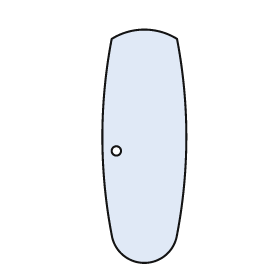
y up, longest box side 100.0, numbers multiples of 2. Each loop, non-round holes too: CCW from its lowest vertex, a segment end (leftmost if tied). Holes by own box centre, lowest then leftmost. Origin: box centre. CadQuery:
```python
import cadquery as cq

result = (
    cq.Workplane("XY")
    .moveTo(-14.0, -38.0)
    .threePointArc((0.0, -50.0), (14.0, -38.0))
    .threePointArc((18.0, 4.0), (14.0, 46.0))
    .threePointArc((0.0, 50.0), (-14.0, 46.0))
    .threePointArc((-18.0, 4.0), (-14.0, -38.0))
    .close()
    .moveTo(-12.0, -2.0)
    .circle(2.0)
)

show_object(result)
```